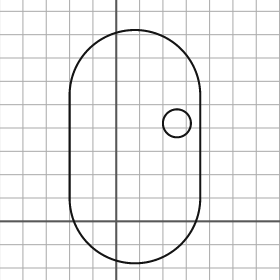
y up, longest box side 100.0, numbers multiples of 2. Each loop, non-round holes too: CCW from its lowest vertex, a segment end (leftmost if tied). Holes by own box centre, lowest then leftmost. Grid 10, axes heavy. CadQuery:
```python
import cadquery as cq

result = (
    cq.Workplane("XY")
    .moveTo(-20.0, 10.0)
    .threePointArc((8.0, -18.0), (36.0, 10.0))
    .lineTo(36.0, 54.0)
    .threePointArc((8.0, 82.0), (-20.0, 54.0))
    .close()
    .moveTo(26.0, 42.0)
    .circle(6.0)
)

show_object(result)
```